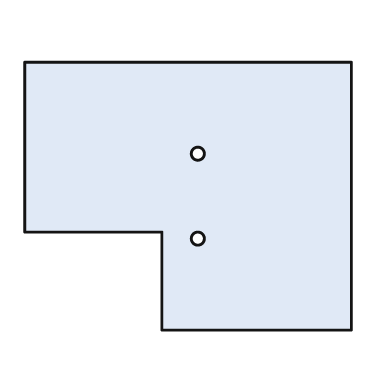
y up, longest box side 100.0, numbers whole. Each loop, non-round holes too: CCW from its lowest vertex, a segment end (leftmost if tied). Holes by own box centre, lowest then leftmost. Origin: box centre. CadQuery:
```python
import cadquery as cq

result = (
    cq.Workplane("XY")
    .moveTo(-8.0, -41.0)
    .lineTo(50.0, -41.0)
    .lineTo(50.0, 41.0)
    .lineTo(-50.0, 41.0)
    .lineTo(-50.0, -11.0)
    .lineTo(-8.0, -11.0)
    .close()
    .moveTo(3.0, -13.0)
    .circle(2.0)
    .moveTo(3.0, 13.0)
    .circle(2.0)
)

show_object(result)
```